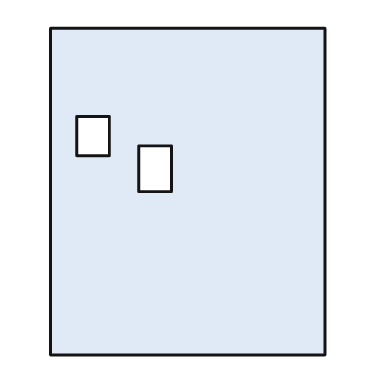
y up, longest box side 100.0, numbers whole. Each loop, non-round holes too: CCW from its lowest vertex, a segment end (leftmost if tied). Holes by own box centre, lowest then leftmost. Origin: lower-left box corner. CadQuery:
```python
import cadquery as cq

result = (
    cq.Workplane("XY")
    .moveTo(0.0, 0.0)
    .lineTo(84.0, 0.0)
    .lineTo(84.0, 100.0)
    .lineTo(0.0, 100.0)
    .close()
    .moveTo(27.0, 50.0)
    .lineTo(37.0, 50.0)
    .lineTo(37.0, 64.0)
    .lineTo(27.0, 64.0)
    .close()
    .moveTo(8.0, 61.0)
    .lineTo(18.0, 61.0)
    .lineTo(18.0, 73.0)
    .lineTo(8.0, 73.0)
    .close()
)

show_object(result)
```